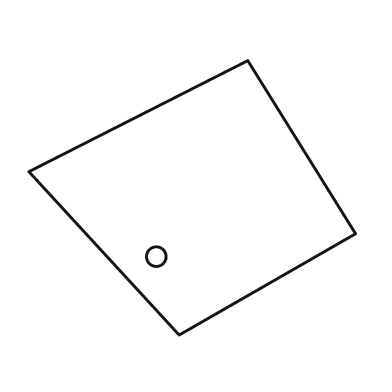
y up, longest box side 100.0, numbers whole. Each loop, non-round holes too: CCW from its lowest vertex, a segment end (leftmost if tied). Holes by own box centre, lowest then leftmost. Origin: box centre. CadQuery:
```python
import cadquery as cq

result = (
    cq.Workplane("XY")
    .moveTo(-4.0, -42.0)
    .lineTo(50.0, -11.0)
    .lineTo(17.0, 42.0)
    .lineTo(-50.0, 8.0)
    .close()
    .moveTo(-11.0, -18.0)
    .circle(3.0)
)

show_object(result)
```